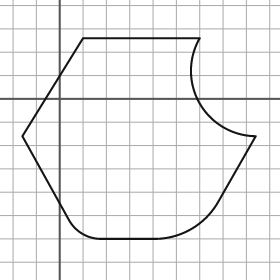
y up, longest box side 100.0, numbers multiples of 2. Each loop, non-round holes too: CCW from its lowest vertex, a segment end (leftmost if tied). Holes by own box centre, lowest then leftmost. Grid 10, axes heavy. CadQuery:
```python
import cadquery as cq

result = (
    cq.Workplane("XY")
    .moveTo(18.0, -60.0)
    .lineTo(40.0, -60.0)
    .threePointArc((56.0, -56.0), (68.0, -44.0))
    .lineTo(84.0, -16.0)
    .threePointArc((60.0, -2.0), (60.0, 26.0))
    .lineTo(10.0, 26.0)
    .lineTo(-16.0, -16.0)
    .lineTo(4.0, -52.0)
    .threePointArc((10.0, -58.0), (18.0, -60.0))
    .close()
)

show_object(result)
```